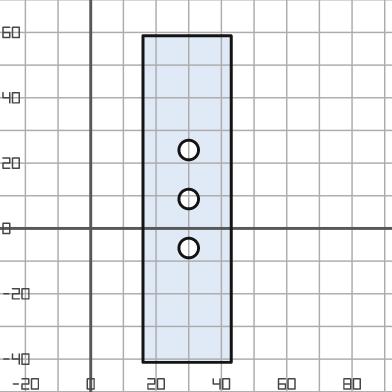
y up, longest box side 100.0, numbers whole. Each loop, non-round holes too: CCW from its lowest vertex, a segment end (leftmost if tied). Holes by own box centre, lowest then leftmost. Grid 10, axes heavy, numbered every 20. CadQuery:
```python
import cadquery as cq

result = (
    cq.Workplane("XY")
    .moveTo(16.0, -41.0)
    .lineTo(43.0, -41.0)
    .lineTo(43.0, 59.0)
    .lineTo(16.0, 59.0)
    .close()
    .moveTo(30.0, -6.0)
    .circle(3.0)
    .moveTo(30.0, 9.0)
    .circle(3.0)
    .moveTo(30.0, 24.0)
    .circle(3.0)
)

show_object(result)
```